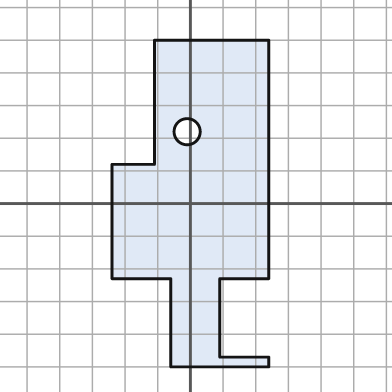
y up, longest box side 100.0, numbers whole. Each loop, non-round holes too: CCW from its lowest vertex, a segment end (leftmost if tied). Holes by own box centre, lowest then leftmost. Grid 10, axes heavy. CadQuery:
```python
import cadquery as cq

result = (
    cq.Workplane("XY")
    .moveTo(-6.0, -50.0)
    .lineTo(24.0, -50.0)
    .lineTo(24.0, -47.0)
    .lineTo(9.0, -47.0)
    .lineTo(9.0, -23.0)
    .lineTo(24.0, -23.0)
    .lineTo(24.0, 50.0)
    .lineTo(-11.0, 50.0)
    .lineTo(-11.0, 12.0)
    .lineTo(-24.0, 12.0)
    .lineTo(-24.0, -23.0)
    .lineTo(-6.0, -23.0)
    .close()
    .moveTo(-1.0, 22.0)
    .circle(4.0)
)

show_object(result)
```